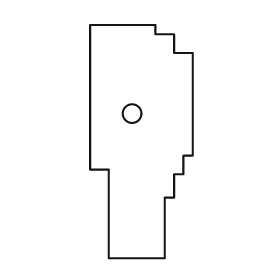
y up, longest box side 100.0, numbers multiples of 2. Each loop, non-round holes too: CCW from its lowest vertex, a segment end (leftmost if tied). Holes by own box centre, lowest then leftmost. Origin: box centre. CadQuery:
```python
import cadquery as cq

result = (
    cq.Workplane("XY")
    .moveTo(-14.0, -50.0)
    .lineTo(10.0, -50.0)
    .lineTo(10.0, -24.0)
    .lineTo(14.0, -24.0)
    .lineTo(14.0, -14.0)
    .lineTo(18.0, -14.0)
    .lineTo(18.0, -6.0)
    .lineTo(22.0, -6.0)
    .lineTo(22.0, 38.0)
    .lineTo(14.0, 38.0)
    .lineTo(14.0, 46.0)
    .lineTo(6.0, 46.0)
    .lineTo(6.0, 50.0)
    .lineTo(-22.0, 50.0)
    .lineTo(-22.0, -12.0)
    .lineTo(-14.0, -12.0)
    .close()
    .moveTo(-4.0, 12.0)
    .circle(4.0)
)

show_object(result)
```